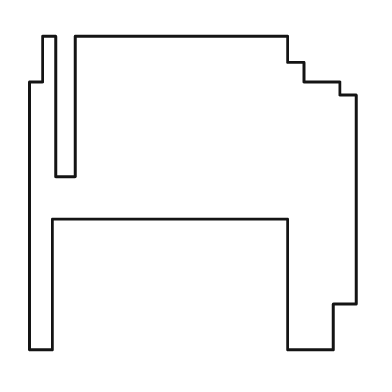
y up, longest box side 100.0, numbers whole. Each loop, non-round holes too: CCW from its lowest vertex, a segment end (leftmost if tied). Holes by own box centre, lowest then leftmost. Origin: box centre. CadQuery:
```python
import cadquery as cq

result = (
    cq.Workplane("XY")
    .moveTo(-50.0, -48.0)
    .lineTo(-43.0, -48.0)
    .lineTo(-43.0, -8.0)
    .lineTo(29.0, -8.0)
    .lineTo(29.0, -48.0)
    .lineTo(43.0, -48.0)
    .lineTo(43.0, -34.0)
    .lineTo(50.0, -34.0)
    .lineTo(50.0, 30.0)
    .lineTo(45.0, 30.0)
    .lineTo(45.0, 34.0)
    .lineTo(34.0, 34.0)
    .lineTo(34.0, 40.0)
    .lineTo(29.0, 40.0)
    .lineTo(29.0, 48.0)
    .lineTo(-36.0, 48.0)
    .lineTo(-36.0, 5.0)
    .lineTo(-42.0, 5.0)
    .lineTo(-42.0, 48.0)
    .lineTo(-46.0, 48.0)
    .lineTo(-46.0, 34.0)
    .lineTo(-50.0, 34.0)
    .close()
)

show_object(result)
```